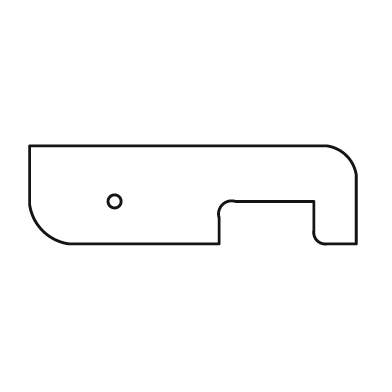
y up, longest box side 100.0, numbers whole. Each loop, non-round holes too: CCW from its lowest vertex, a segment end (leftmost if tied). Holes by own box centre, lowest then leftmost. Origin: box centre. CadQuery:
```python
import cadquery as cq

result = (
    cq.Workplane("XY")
    .moveTo(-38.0, -15.0)
    .lineTo(8.0, -15.0)
    .lineTo(8.0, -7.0)
    .threePointArc((9.0, -3.0), (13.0, -2.0))
    .lineTo(37.0, -2.0)
    .lineTo(37.0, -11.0)
    .threePointArc((38.0, -14.0), (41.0, -15.0))
    .lineTo(50.0, -15.0)
    .lineTo(50.0, 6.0)
    .threePointArc((47.0, 12.0), (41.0, 15.0))
    .lineTo(-50.0, 15.0)
    .lineTo(-50.0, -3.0)
    .threePointArc((-46.0, -11.0), (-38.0, -15.0))
    .close()
    .moveTo(-24.0, -2.0)
    .circle(2.0)
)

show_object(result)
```